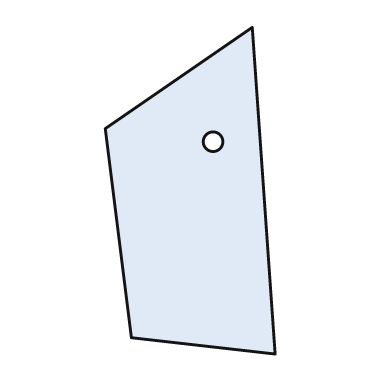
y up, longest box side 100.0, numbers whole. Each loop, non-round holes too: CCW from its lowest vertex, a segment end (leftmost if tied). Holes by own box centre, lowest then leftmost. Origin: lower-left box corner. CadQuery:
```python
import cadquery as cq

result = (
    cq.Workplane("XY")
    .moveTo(52.0, 0.0)
    .lineTo(45.0, 100.0)
    .lineTo(0.0, 69.0)
    .lineTo(8.0, 5.0)
    .close()
    .moveTo(33.0, 65.0)
    .circle(3.0)
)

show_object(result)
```